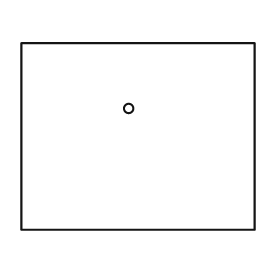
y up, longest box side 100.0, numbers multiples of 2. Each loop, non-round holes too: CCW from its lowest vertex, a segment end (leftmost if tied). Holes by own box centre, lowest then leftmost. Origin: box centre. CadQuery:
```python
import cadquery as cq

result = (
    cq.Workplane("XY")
    .moveTo(-50.0, -40.0)
    .lineTo(50.0, -40.0)
    .lineTo(50.0, 40.0)
    .lineTo(-50.0, 40.0)
    .close()
    .moveTo(-4.0, 12.0)
    .circle(2.0)
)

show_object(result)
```